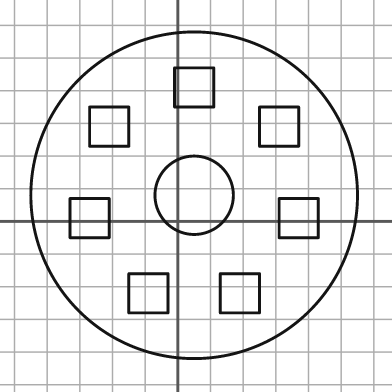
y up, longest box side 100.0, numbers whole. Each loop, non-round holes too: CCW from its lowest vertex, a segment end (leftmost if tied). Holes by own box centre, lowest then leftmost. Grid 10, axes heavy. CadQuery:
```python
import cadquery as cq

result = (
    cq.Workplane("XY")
    .moveTo(5.0, 8.0)
    .circle(50.0)
    .moveTo(-15.0, -28.0)
    .lineTo(-3.0, -28.0)
    .lineTo(-3.0, -16.0)
    .lineTo(-15.0, -16.0)
    .close()
    .moveTo(13.0, -28.0)
    .lineTo(25.0, -28.0)
    .lineTo(25.0, -16.0)
    .lineTo(13.0, -16.0)
    .close()
    .moveTo(-33.0, -5.0)
    .lineTo(-21.0, -5.0)
    .lineTo(-21.0, 7.0)
    .lineTo(-33.0, 7.0)
    .close()
    .moveTo(31.0, -5.0)
    .lineTo(43.0, -5.0)
    .lineTo(43.0, 7.0)
    .lineTo(31.0, 7.0)
    .close()
    .moveTo(5.0, 8.0)
    .circle(12.0)
    .moveTo(-27.0, 23.0)
    .lineTo(-15.0, 23.0)
    .lineTo(-15.0, 35.0)
    .lineTo(-27.0, 35.0)
    .close()
    .moveTo(25.0, 23.0)
    .lineTo(37.0, 23.0)
    .lineTo(37.0, 35.0)
    .lineTo(25.0, 35.0)
    .close()
    .moveTo(-1.0, 35.0)
    .lineTo(11.0, 35.0)
    .lineTo(11.0, 47.0)
    .lineTo(-1.0, 47.0)
    .close()
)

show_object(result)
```